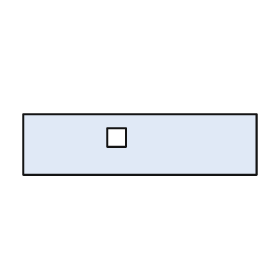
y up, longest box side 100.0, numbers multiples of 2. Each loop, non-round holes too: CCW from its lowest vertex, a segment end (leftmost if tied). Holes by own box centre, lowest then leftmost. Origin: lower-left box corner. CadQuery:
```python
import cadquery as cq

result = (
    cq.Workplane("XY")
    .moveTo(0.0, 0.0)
    .lineTo(100.0, 0.0)
    .lineTo(100.0, 26.0)
    .lineTo(0.0, 26.0)
    .close()
    .moveTo(36.0, 12.0)
    .lineTo(44.0, 12.0)
    .lineTo(44.0, 20.0)
    .lineTo(36.0, 20.0)
    .close()
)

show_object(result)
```